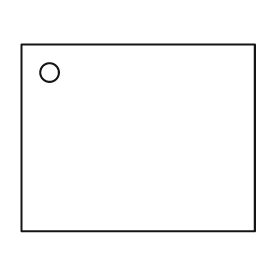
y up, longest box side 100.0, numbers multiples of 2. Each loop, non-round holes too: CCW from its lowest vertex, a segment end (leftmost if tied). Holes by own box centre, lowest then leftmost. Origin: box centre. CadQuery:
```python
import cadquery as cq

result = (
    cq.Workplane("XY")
    .moveTo(-50.0, -40.0)
    .lineTo(50.0, -40.0)
    .lineTo(50.0, 40.0)
    .lineTo(-50.0, 40.0)
    .close()
    .moveTo(-38.0, 28.0)
    .circle(4.0)
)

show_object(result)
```